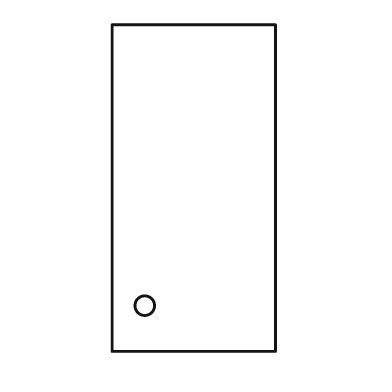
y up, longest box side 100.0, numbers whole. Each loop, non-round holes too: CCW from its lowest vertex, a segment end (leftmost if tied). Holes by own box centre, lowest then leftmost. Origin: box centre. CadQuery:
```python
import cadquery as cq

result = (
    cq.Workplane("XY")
    .moveTo(-25.0, -50.0)
    .lineTo(25.0, -50.0)
    .lineTo(25.0, 50.0)
    .lineTo(-25.0, 50.0)
    .close()
    .moveTo(-15.0, -36.0)
    .circle(3.0)
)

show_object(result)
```